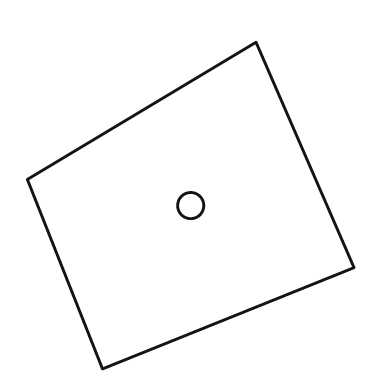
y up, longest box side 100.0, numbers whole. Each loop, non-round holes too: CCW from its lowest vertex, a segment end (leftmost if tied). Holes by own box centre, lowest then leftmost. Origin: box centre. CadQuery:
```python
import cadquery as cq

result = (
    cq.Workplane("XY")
    .moveTo(-27.0, -50.0)
    .lineTo(50.0, -19.0)
    .lineTo(20.0, 50.0)
    .lineTo(-50.0, 8.0)
    .close()
    .moveTo(0.0, 0.0)
    .circle(4.0)
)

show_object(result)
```